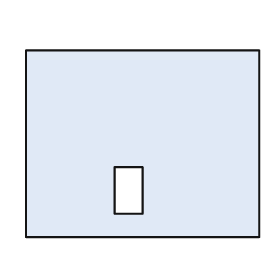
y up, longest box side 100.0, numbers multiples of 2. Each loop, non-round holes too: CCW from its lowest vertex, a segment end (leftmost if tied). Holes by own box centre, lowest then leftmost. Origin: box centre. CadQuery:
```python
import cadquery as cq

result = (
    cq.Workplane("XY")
    .moveTo(-50.0, -40.0)
    .lineTo(50.0, -40.0)
    .lineTo(50.0, 40.0)
    .lineTo(-50.0, 40.0)
    .close()
    .moveTo(-12.0, -30.0)
    .lineTo(0.0, -30.0)
    .lineTo(0.0, -10.0)
    .lineTo(-12.0, -10.0)
    .close()
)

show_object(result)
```